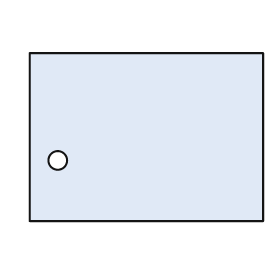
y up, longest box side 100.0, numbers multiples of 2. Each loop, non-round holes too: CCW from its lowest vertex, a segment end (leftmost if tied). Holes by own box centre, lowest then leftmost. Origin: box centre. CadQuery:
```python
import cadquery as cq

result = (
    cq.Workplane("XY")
    .moveTo(-50.0, -36.0)
    .lineTo(50.0, -36.0)
    .lineTo(50.0, 36.0)
    .lineTo(-50.0, 36.0)
    .close()
    .moveTo(-38.0, -10.0)
    .circle(4.0)
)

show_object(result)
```